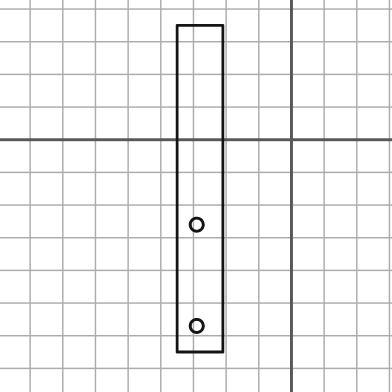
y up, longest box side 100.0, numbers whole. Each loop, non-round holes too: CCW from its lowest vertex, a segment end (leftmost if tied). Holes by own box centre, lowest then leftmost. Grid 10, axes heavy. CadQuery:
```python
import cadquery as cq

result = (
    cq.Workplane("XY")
    .moveTo(-35.0, -65.0)
    .lineTo(-21.0, -65.0)
    .lineTo(-21.0, 35.0)
    .lineTo(-35.0, 35.0)
    .close()
    .moveTo(-29.0, -57.0)
    .circle(2.0)
    .moveTo(-29.0, -26.0)
    .circle(2.0)
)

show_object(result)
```